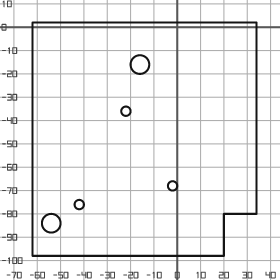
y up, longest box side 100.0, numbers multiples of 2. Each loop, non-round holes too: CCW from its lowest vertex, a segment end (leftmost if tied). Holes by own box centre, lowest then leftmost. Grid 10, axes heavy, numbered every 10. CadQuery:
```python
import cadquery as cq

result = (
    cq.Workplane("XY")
    .moveTo(-62.0, -98.0)
    .lineTo(20.0, -98.0)
    .lineTo(20.0, -80.0)
    .lineTo(34.0, -80.0)
    .lineTo(34.0, 2.0)
    .lineTo(-62.0, 2.0)
    .close()
    .moveTo(-54.0, -84.0)
    .circle(4.0)
    .moveTo(-42.0, -76.0)
    .circle(2.0)
    .moveTo(-2.0, -68.0)
    .circle(2.0)
    .moveTo(-22.0, -36.0)
    .circle(2.0)
    .moveTo(-16.0, -16.0)
    .circle(4.0)
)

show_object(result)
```